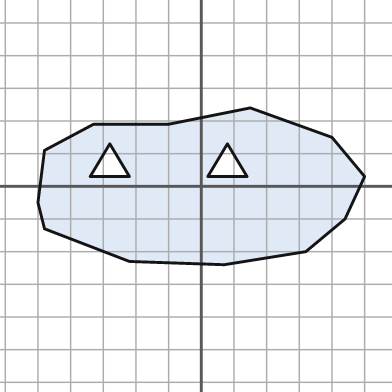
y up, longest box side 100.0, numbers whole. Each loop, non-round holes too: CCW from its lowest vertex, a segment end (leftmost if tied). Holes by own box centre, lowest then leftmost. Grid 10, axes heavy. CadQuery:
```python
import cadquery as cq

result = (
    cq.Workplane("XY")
    .moveTo(7.0, -24.0)
    .lineTo(32.0, -20.0)
    .lineTo(44.0, -10.0)
    .lineTo(50.0, 3.0)
    .lineTo(40.0, 15.0)
    .lineTo(15.0, 24.0)
    .lineTo(-10.0, 19.0)
    .lineTo(-33.0, 19.0)
    .lineTo(-48.0, 11.0)
    .lineTo(-50.0, -5.0)
    .lineTo(-48.0, -13.0)
    .lineTo(-22.0, -23.0)
    .close()
    .moveTo(-34.0, 3.0)
    .lineTo(-22.0, 3.0)
    .lineTo(-28.0, 13.0)
    .close()
    .moveTo(2.0, 3.0)
    .lineTo(14.0, 3.0)
    .lineTo(8.0, 13.0)
    .close()
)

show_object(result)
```